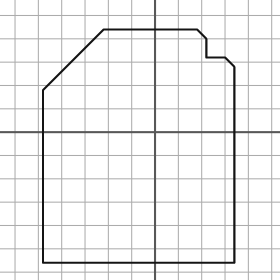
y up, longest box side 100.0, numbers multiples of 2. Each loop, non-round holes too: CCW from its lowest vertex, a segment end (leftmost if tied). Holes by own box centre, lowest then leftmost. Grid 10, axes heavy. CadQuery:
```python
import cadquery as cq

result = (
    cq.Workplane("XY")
    .moveTo(-48.0, -56.0)
    .lineTo(34.0, -56.0)
    .lineTo(34.0, 28.0)
    .lineTo(30.0, 32.0)
    .lineTo(22.0, 32.0)
    .lineTo(22.0, 40.0)
    .lineTo(18.0, 44.0)
    .lineTo(-22.0, 44.0)
    .lineTo(-48.0, 18.0)
    .close()
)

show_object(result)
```